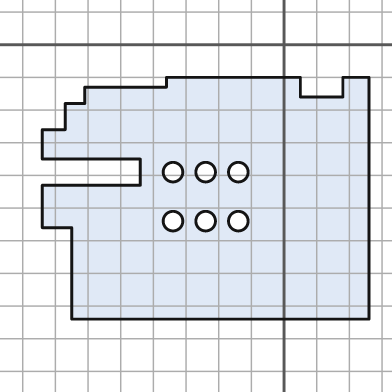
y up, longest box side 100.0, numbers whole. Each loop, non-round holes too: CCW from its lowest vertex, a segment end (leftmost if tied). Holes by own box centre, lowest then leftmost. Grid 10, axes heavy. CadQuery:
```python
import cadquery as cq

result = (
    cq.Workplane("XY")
    .moveTo(-65.0, -84.0)
    .lineTo(26.0, -84.0)
    .lineTo(26.0, -10.0)
    .lineTo(18.0, -10.0)
    .lineTo(18.0, -16.0)
    .lineTo(5.0, -16.0)
    .lineTo(5.0, -10.0)
    .lineTo(-36.0, -10.0)
    .lineTo(-36.0, -13.0)
    .lineTo(-61.0, -13.0)
    .lineTo(-61.0, -18.0)
    .lineTo(-67.0, -18.0)
    .lineTo(-67.0, -26.0)
    .lineTo(-74.0, -26.0)
    .lineTo(-74.0, -35.0)
    .lineTo(-44.0, -35.0)
    .lineTo(-44.0, -43.0)
    .lineTo(-74.0, -43.0)
    .lineTo(-74.0, -56.0)
    .lineTo(-65.0, -56.0)
    .close()
    .moveTo(-34.0, -54.0)
    .circle(3.0)
    .moveTo(-24.0, -54.0)
    .circle(3.0)
    .moveTo(-14.0, -54.0)
    .circle(3.0)
    .moveTo(-34.0, -39.0)
    .circle(3.0)
    .moveTo(-24.0, -39.0)
    .circle(3.0)
    .moveTo(-14.0, -39.0)
    .circle(3.0)
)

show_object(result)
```